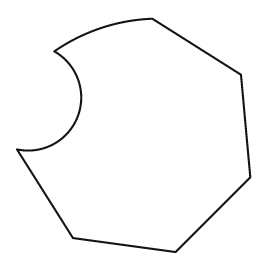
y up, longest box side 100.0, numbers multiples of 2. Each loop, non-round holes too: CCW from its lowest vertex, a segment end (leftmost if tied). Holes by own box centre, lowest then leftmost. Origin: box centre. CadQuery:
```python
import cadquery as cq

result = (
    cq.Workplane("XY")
    .moveTo(18.0, -50.0)
    .lineTo(50.0, -18.0)
    .lineTo(46.0, 26.0)
    .lineTo(8.0, 50.0)
    .threePointArc((-14.0, 46.0), (-34.0, 36.0))
    .threePointArc((-24.0, 8.0), (-50.0, -6.0))
    .lineTo(-26.0, -44.0)
    .close()
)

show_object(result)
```